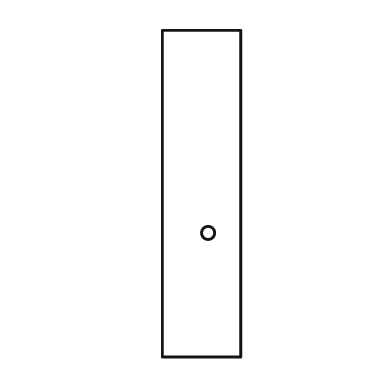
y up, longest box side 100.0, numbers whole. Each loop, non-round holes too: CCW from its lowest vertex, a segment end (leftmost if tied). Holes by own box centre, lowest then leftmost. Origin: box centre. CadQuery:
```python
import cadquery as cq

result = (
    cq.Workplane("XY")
    .moveTo(-12.0, -50.0)
    .lineTo(12.0, -50.0)
    .lineTo(12.0, 50.0)
    .lineTo(-12.0, 50.0)
    .close()
    .moveTo(2.0, -12.0)
    .circle(2.0)
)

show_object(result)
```